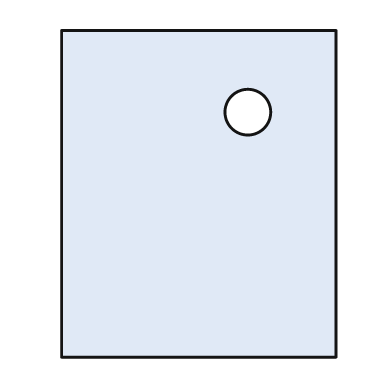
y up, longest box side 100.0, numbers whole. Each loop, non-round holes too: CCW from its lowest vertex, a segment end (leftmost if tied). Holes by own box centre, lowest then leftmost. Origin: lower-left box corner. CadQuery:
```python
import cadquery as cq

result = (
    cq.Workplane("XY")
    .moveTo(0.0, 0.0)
    .lineTo(84.0, 0.0)
    .lineTo(84.0, 100.0)
    .lineTo(0.0, 100.0)
    .close()
    .moveTo(57.0, 75.0)
    .circle(7.0)
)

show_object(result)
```